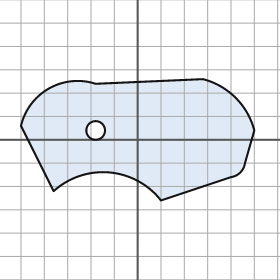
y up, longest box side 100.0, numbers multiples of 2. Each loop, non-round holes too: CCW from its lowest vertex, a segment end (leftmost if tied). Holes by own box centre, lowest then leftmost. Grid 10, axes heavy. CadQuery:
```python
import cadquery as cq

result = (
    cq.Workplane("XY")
    .moveTo(10.0, -26.0)
    .lineTo(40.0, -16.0)
    .threePointArc((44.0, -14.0), (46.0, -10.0))
    .lineTo(50.0, 4.0)
    .threePointArc((42.0, 18.0), (28.0, 26.0))
    .lineTo(-18.0, 24.0)
    .threePointArc((-38.0, 22.0), (-50.0, 6.0))
    .lineTo(-36.0, -22.0)
    .threePointArc((-12.0, -14.0), (10.0, -26.0))
    .close()
    .moveTo(-18.0, 4.0)
    .circle(4.0)
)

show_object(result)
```